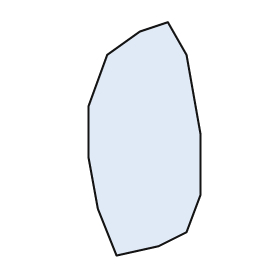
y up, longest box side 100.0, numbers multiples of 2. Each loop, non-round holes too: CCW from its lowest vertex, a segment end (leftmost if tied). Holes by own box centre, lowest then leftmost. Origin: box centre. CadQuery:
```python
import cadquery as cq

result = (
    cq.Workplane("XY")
    .moveTo(-12.0, -50.0)
    .lineTo(6.0, -46.0)
    .lineTo(18.0, -40.0)
    .lineTo(24.0, -24.0)
    .lineTo(24.0, 2.0)
    .lineTo(18.0, 36.0)
    .lineTo(10.0, 50.0)
    .lineTo(-2.0, 46.0)
    .lineTo(-16.0, 36.0)
    .lineTo(-24.0, 14.0)
    .lineTo(-24.0, -8.0)
    .lineTo(-20.0, -30.0)
    .close()
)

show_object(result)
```